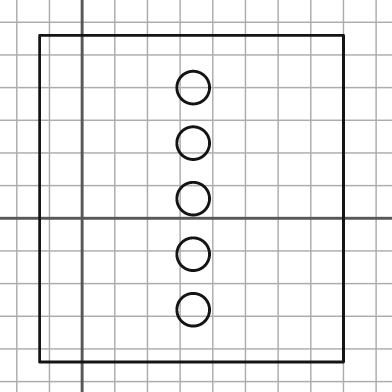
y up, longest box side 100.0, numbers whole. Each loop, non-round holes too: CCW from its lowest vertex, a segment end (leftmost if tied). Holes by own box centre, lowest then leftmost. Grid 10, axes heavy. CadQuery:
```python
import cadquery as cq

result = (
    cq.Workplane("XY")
    .moveTo(-13.0, -44.0)
    .lineTo(80.0, -44.0)
    .lineTo(80.0, 56.0)
    .lineTo(-13.0, 56.0)
    .close()
    .moveTo(34.0, -28.0)
    .circle(5.0)
    .moveTo(34.0, -11.0)
    .circle(5.0)
    .moveTo(34.0, 6.0)
    .circle(5.0)
    .moveTo(34.0, 23.0)
    .circle(5.0)
    .moveTo(34.0, 40.0)
    .circle(5.0)
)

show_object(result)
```